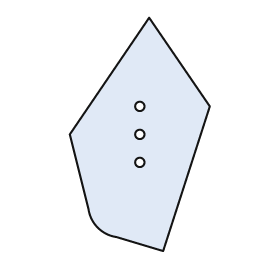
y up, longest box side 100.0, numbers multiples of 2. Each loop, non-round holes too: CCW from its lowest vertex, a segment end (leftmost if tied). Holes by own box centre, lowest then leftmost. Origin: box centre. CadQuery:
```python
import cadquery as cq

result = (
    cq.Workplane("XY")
    .moveTo(10.0, -50.0)
    .lineTo(30.0, 12.0)
    .lineTo(4.0, 50.0)
    .lineTo(-30.0, 0.0)
    .lineTo(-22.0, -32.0)
    .threePointArc((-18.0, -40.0), (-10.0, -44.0))
    .close()
    .moveTo(0.0, -12.0)
    .circle(2.0)
    .moveTo(0.0, 0.0)
    .circle(2.0)
    .moveTo(0.0, 12.0)
    .circle(2.0)
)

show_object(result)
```